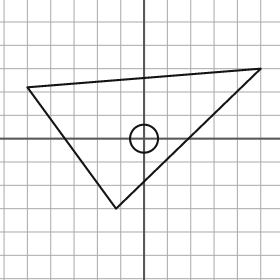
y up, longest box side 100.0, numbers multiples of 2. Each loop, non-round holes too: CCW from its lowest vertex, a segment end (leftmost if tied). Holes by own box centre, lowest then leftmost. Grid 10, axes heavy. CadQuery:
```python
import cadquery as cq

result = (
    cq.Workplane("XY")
    .moveTo(-12.0, -30.0)
    .lineTo(50.0, 30.0)
    .lineTo(-50.0, 22.0)
    .close()
    .moveTo(0.0, 0.0)
    .circle(6.0)
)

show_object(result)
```